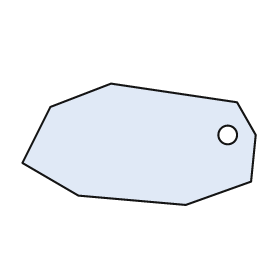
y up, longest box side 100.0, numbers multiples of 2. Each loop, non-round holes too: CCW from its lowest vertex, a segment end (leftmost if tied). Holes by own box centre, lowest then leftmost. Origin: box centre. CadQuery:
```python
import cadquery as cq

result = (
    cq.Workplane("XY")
    .moveTo(20.0, -26.0)
    .lineTo(48.0, -16.0)
    .lineTo(50.0, 4.0)
    .lineTo(42.0, 18.0)
    .lineTo(-12.0, 26.0)
    .lineTo(-38.0, 16.0)
    .lineTo(-50.0, -8.0)
    .lineTo(-26.0, -22.0)
    .close()
    .moveTo(38.0, 4.0)
    .circle(4.0)
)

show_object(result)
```